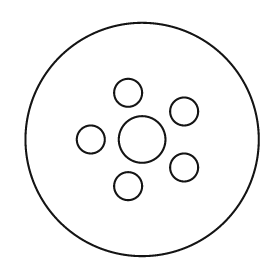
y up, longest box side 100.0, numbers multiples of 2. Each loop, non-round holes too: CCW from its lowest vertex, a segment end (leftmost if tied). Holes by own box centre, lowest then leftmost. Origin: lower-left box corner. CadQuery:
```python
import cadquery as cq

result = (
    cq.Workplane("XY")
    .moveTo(50.0, 50.0)
    .circle(50.0)
    .moveTo(44.0, 30.0)
    .circle(6.0)
    .moveTo(68.0, 38.0)
    .circle(6.0)
    .moveTo(28.0, 50.0)
    .circle(6.0)
    .moveTo(50.0, 50.0)
    .circle(10.0)
    .moveTo(68.0, 62.0)
    .circle(6.0)
    .moveTo(44.0, 70.0)
    .circle(6.0)
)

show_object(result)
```